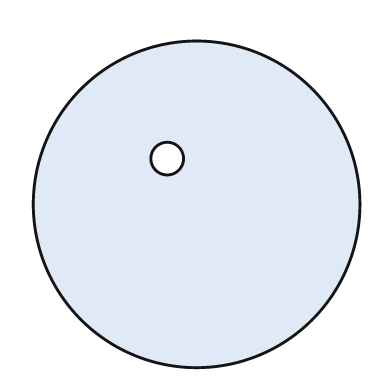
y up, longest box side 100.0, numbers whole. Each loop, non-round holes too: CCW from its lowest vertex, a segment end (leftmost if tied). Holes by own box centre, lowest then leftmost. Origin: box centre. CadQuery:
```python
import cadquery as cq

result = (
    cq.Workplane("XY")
    .moveTo(0.0, 0.0)
    .circle(50.0)
    .moveTo(-9.0, 14.0)
    .circle(5.0)
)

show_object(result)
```